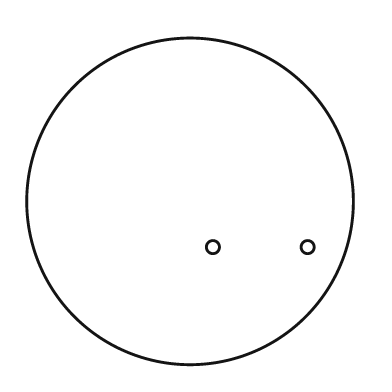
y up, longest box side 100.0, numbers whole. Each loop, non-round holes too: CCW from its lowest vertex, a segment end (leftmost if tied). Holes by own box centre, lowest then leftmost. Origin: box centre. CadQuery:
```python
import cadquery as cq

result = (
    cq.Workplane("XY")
    .moveTo(0.0, 0.0)
    .circle(50.0)
    .moveTo(7.0, -14.0)
    .circle(2.0)
    .moveTo(36.0, -14.0)
    .circle(2.0)
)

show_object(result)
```